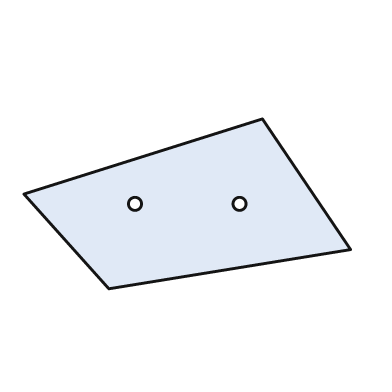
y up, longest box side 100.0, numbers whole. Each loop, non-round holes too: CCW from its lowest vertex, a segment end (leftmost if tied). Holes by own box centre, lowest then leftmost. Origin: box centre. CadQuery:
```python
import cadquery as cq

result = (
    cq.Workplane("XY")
    .moveTo(-24.0, -26.0)
    .lineTo(50.0, -14.0)
    .lineTo(23.0, 26.0)
    .lineTo(-50.0, 3.0)
    .close()
    .moveTo(-16.0, 0.0)
    .circle(2.0)
    .moveTo(16.0, 0.0)
    .circle(2.0)
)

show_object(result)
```